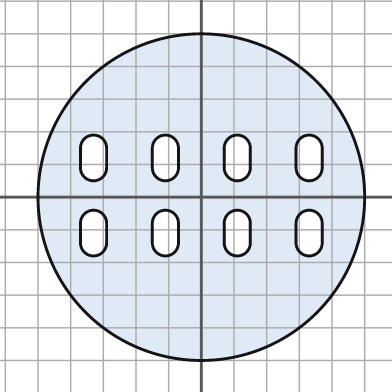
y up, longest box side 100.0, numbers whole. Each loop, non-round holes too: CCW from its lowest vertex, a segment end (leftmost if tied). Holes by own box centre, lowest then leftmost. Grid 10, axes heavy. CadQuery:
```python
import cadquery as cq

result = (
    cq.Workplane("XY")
    .moveTo(0.0, 0.0)
    .circle(50.0)
    .moveTo(-37.0, -14.0)
    .threePointArc((-33.0, -18.0), (-29.0, -14.0))
    .lineTo(-29.0, -8.0)
    .threePointArc((-33.0, -4.0), (-37.0, -8.0))
    .close()
    .moveTo(-15.0, -14.0)
    .threePointArc((-11.0, -18.0), (-7.0, -14.0))
    .lineTo(-7.0, -8.0)
    .threePointArc((-11.0, -4.0), (-15.0, -8.0))
    .close()
    .moveTo(7.0, -14.0)
    .threePointArc((11.0, -18.0), (15.0, -14.0))
    .lineTo(15.0, -8.0)
    .threePointArc((11.0, -4.0), (7.0, -8.0))
    .close()
    .moveTo(29.0, -14.0)
    .threePointArc((33.0, -18.0), (37.0, -14.0))
    .lineTo(37.0, -8.0)
    .threePointArc((33.0, -4.0), (29.0, -8.0))
    .close()
    .moveTo(-37.0, 9.0)
    .threePointArc((-33.0, 5.0), (-29.0, 9.0))
    .lineTo(-29.0, 15.0)
    .threePointArc((-33.0, 19.0), (-37.0, 15.0))
    .close()
    .moveTo(-15.0, 9.0)
    .threePointArc((-11.0, 5.0), (-7.0, 9.0))
    .lineTo(-7.0, 15.0)
    .threePointArc((-11.0, 19.0), (-15.0, 15.0))
    .close()
    .moveTo(7.0, 9.0)
    .threePointArc((11.0, 5.0), (15.0, 9.0))
    .lineTo(15.0, 15.0)
    .threePointArc((11.0, 19.0), (7.0, 15.0))
    .close()
    .moveTo(29.0, 9.0)
    .threePointArc((33.0, 5.0), (37.0, 9.0))
    .lineTo(37.0, 15.0)
    .threePointArc((33.0, 19.0), (29.0, 15.0))
    .close()
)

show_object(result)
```